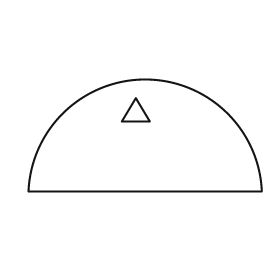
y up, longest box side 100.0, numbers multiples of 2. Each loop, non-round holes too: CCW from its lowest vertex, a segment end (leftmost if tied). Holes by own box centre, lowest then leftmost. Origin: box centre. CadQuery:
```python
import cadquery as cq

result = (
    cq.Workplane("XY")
    .moveTo(-50.0, -24.0)
    .lineTo(50.0, -24.0)
    .threePointArc((0.0, 24.0), (-50.0, -24.0))
    .close()
    .moveTo(-10.0, 6.0)
    .lineTo(2.0, 6.0)
    .lineTo(-4.0, 16.0)
    .close()
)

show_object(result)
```